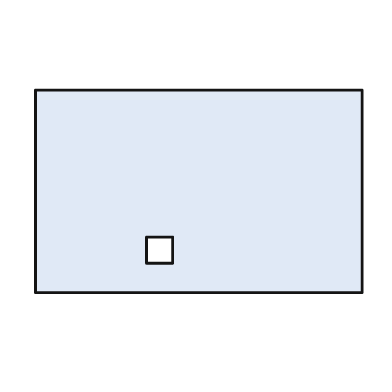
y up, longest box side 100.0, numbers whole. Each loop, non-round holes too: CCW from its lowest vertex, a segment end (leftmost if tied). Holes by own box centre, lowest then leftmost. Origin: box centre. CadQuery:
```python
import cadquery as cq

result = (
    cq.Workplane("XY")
    .moveTo(-50.0, -31.0)
    .lineTo(50.0, -31.0)
    .lineTo(50.0, 31.0)
    .lineTo(-50.0, 31.0)
    .close()
    .moveTo(-16.0, -22.0)
    .lineTo(-8.0, -22.0)
    .lineTo(-8.0, -14.0)
    .lineTo(-16.0, -14.0)
    .close()
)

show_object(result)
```